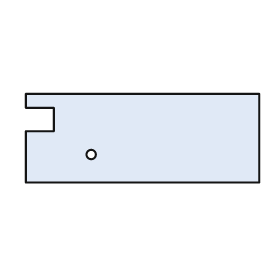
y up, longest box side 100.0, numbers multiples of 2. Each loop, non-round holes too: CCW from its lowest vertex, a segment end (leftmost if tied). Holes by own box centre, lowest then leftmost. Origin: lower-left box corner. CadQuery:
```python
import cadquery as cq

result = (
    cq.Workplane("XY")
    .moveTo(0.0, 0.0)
    .lineTo(100.0, 0.0)
    .lineTo(100.0, 38.0)
    .lineTo(0.0, 38.0)
    .lineTo(0.0, 32.0)
    .lineTo(12.0, 32.0)
    .lineTo(12.0, 22.0)
    .lineTo(0.0, 22.0)
    .close()
    .moveTo(28.0, 12.0)
    .circle(2.0)
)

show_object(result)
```